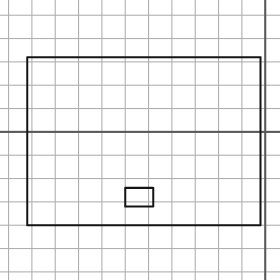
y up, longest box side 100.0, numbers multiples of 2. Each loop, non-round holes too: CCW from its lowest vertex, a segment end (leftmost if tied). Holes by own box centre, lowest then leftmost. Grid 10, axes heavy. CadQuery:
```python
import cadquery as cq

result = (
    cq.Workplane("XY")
    .moveTo(-102.0, -40.0)
    .lineTo(-2.0, -40.0)
    .lineTo(-2.0, 32.0)
    .lineTo(-102.0, 32.0)
    .close()
    .moveTo(-60.0, -32.0)
    .lineTo(-48.0, -32.0)
    .lineTo(-48.0, -24.0)
    .lineTo(-60.0, -24.0)
    .close()
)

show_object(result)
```